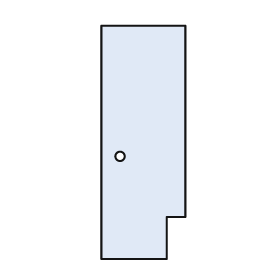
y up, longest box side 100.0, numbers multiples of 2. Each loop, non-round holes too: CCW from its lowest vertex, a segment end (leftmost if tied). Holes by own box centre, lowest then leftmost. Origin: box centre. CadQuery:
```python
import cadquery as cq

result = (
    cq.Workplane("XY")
    .moveTo(-18.0, -50.0)
    .lineTo(10.0, -50.0)
    .lineTo(10.0, -32.0)
    .lineTo(18.0, -32.0)
    .lineTo(18.0, 50.0)
    .lineTo(-18.0, 50.0)
    .close()
    .moveTo(-10.0, -6.0)
    .circle(2.0)
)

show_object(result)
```